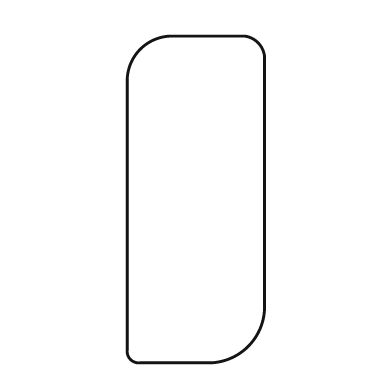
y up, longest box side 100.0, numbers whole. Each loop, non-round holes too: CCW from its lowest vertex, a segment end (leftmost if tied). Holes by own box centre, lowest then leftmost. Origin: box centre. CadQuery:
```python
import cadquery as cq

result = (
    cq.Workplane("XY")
    .moveTo(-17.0, -50.0)
    .lineTo(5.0, -50.0)
    .threePointArc((16.0, -45.0), (21.0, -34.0))
    .lineTo(21.0, 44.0)
    .threePointArc((19.0, 48.0), (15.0, 50.0))
    .lineTo(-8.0, 50.0)
    .threePointArc((-17.0, 46.0), (-21.0, 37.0))
    .lineTo(-21.0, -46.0)
    .threePointArc((-20.0, -49.0), (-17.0, -50.0))
    .close()
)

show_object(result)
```